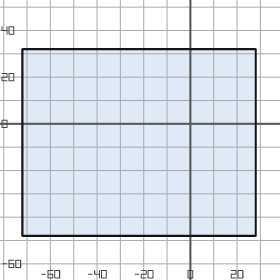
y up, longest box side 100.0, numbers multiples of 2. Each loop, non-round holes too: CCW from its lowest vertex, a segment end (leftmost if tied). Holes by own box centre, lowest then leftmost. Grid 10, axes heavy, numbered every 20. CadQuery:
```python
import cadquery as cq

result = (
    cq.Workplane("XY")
    .moveTo(-72.0, -48.0)
    .lineTo(28.0, -48.0)
    .lineTo(28.0, 32.0)
    .lineTo(-72.0, 32.0)
    .close()
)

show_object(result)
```